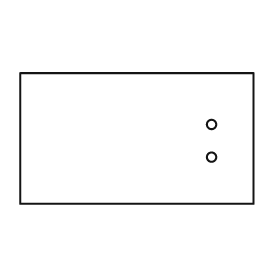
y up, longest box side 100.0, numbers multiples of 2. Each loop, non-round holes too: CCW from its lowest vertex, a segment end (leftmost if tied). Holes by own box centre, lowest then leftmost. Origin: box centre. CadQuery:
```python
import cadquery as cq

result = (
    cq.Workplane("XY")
    .moveTo(-50.0, -28.0)
    .lineTo(50.0, -28.0)
    .lineTo(50.0, 28.0)
    .lineTo(-50.0, 28.0)
    .close()
    .moveTo(32.0, -8.0)
    .circle(2.0)
    .moveTo(32.0, 6.0)
    .circle(2.0)
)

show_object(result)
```